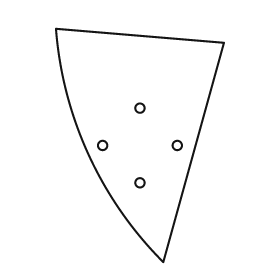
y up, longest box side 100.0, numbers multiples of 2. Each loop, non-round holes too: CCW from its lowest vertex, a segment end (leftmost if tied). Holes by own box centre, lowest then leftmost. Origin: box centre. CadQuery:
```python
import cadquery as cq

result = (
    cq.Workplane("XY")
    .moveTo(10.0, -50.0)
    .lineTo(36.0, 44.0)
    .lineTo(-36.0, 50.0)
    .threePointArc((-22.0, -4.0), (10.0, -50.0))
    .close()
    .moveTo(0.0, -16.0)
    .circle(2.0)
    .moveTo(-16.0, 0.0)
    .circle(2.0)
    .moveTo(16.0, 0.0)
    .circle(2.0)
    .moveTo(0.0, 16.0)
    .circle(2.0)
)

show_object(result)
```